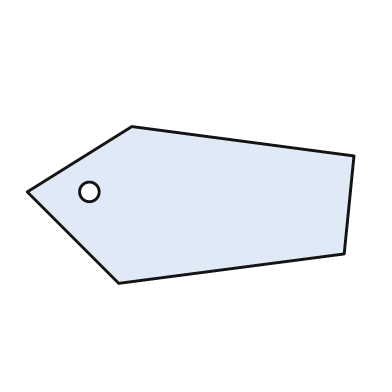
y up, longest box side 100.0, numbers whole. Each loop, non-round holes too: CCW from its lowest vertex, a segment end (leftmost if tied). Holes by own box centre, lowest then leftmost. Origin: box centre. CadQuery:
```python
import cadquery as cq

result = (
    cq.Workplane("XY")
    .moveTo(-22.0, -24.0)
    .lineTo(47.0, -15.0)
    .lineTo(50.0, 15.0)
    .lineTo(-18.0, 24.0)
    .lineTo(-50.0, 4.0)
    .close()
    .moveTo(-31.0, 4.0)
    .circle(3.0)
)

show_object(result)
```